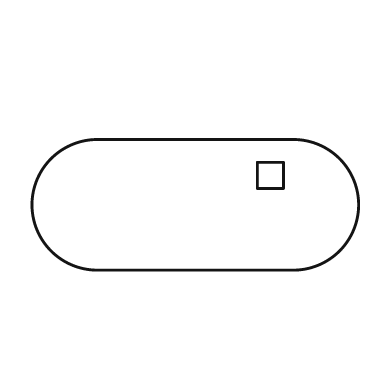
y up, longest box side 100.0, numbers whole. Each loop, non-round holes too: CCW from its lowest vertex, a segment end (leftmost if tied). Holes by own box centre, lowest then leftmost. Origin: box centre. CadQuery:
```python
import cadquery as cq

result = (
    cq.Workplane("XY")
    .moveTo(-30.0, -20.0)
    .lineTo(30.0, -20.0)
    .threePointArc((50.0, 0.0), (30.0, 20.0))
    .lineTo(-30.0, 20.0)
    .threePointArc((-50.0, 0.0), (-30.0, -20.0))
    .close()
    .moveTo(19.0, 5.0)
    .lineTo(27.0, 5.0)
    .lineTo(27.0, 13.0)
    .lineTo(19.0, 13.0)
    .close()
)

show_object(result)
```